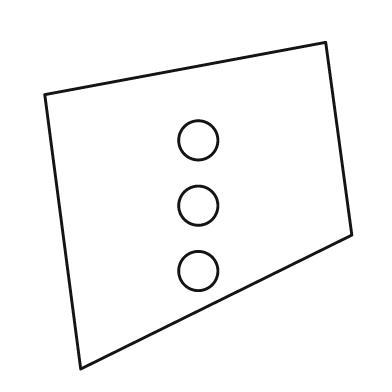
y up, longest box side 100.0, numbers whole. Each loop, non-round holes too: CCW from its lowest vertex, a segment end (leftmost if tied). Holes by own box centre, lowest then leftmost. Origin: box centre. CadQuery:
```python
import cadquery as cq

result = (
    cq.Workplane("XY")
    .moveTo(-36.0, -50.0)
    .lineTo(47.0, -9.0)
    .lineTo(39.0, 50.0)
    .lineTo(-47.0, 34.0)
    .close()
    .moveTo(0.0, -20.0)
    .circle(6.0)
    .moveTo(0.0, 0.0)
    .circle(6.0)
    .moveTo(0.0, 20.0)
    .circle(6.0)
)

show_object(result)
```